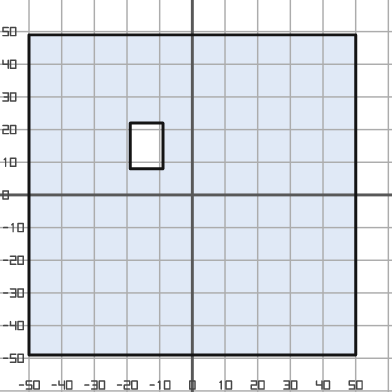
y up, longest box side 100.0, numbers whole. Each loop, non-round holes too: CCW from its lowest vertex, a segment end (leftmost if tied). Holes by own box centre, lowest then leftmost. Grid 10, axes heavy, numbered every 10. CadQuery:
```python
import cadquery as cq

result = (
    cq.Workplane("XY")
    .moveTo(-50.0, -49.0)
    .lineTo(50.0, -49.0)
    .lineTo(50.0, 49.0)
    .lineTo(-50.0, 49.0)
    .close()
    .moveTo(-19.0, 8.0)
    .lineTo(-9.0, 8.0)
    .lineTo(-9.0, 22.0)
    .lineTo(-19.0, 22.0)
    .close()
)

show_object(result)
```